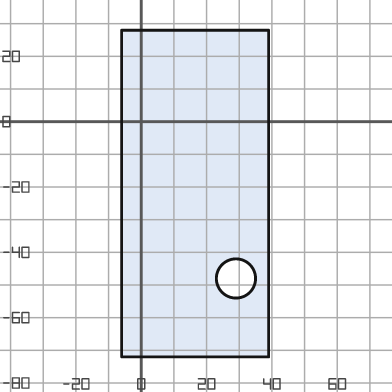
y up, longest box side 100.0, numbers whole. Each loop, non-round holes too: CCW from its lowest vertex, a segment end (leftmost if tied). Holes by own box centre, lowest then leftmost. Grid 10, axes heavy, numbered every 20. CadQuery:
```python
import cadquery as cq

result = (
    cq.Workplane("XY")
    .moveTo(-6.0, -72.0)
    .lineTo(39.0, -72.0)
    .lineTo(39.0, 28.0)
    .lineTo(-6.0, 28.0)
    .close()
    .moveTo(29.0, -48.0)
    .circle(6.0)
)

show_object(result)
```